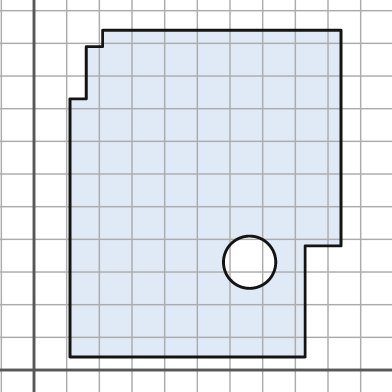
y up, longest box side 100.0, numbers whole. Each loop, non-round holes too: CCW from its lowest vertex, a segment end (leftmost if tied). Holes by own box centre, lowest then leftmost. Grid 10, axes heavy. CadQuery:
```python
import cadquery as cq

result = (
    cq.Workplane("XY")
    .moveTo(11.0, 4.0)
    .lineTo(83.0, 4.0)
    .lineTo(83.0, 38.0)
    .lineTo(94.0, 38.0)
    .lineTo(94.0, 104.0)
    .lineTo(21.0, 104.0)
    .lineTo(21.0, 99.0)
    .lineTo(16.0, 99.0)
    .lineTo(16.0, 83.0)
    .lineTo(11.0, 83.0)
    .close()
    .moveTo(66.0, 33.0)
    .circle(8.0)
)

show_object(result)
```